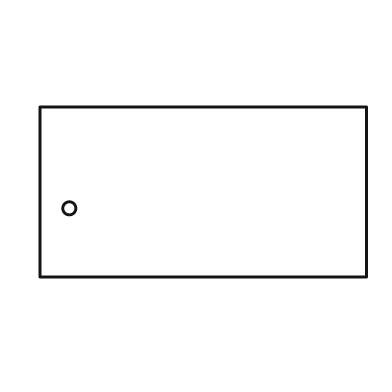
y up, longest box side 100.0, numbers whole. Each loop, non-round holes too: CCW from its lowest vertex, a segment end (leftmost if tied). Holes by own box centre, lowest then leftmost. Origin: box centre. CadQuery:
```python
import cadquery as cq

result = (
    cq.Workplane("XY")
    .moveTo(-50.0, -26.0)
    .lineTo(50.0, -26.0)
    .lineTo(50.0, 26.0)
    .lineTo(-50.0, 26.0)
    .close()
    .moveTo(-41.0, -5.0)
    .circle(2.0)
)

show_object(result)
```